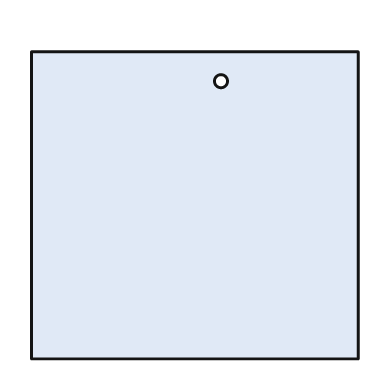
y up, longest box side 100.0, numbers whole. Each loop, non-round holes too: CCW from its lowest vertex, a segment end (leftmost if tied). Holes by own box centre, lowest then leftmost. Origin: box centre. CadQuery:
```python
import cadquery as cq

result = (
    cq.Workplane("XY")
    .moveTo(-50.0, -47.0)
    .lineTo(50.0, -47.0)
    .lineTo(50.0, 47.0)
    .lineTo(-50.0, 47.0)
    .close()
    .moveTo(8.0, 38.0)
    .circle(2.0)
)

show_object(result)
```